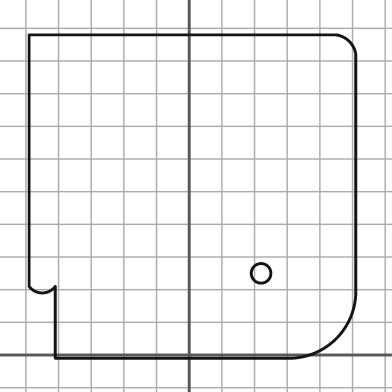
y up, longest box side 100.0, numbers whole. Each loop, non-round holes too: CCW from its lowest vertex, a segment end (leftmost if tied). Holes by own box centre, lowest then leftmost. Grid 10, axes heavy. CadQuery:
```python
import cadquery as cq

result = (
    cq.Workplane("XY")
    .moveTo(-41.0, -1.0)
    .lineTo(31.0, -1.0)
    .threePointArc((45.0, 5.0), (51.0, 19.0))
    .lineTo(51.0, 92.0)
    .threePointArc((49.0, 96.0), (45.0, 98.0))
    .lineTo(-49.0, 98.0)
    .lineTo(-49.0, 21.0)
    .threePointArc((-45.0, 19.0), (-41.0, 21.0))
    .close()
    .moveTo(22.0, 25.0)
    .circle(3.0)
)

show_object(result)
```